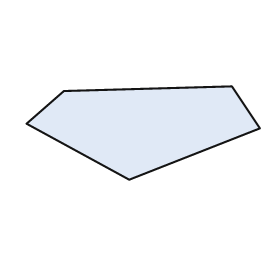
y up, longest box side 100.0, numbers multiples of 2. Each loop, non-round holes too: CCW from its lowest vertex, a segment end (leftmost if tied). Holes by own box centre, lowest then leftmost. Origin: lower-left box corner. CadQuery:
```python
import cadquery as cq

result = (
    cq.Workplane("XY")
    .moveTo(44.0, 0.0)
    .lineTo(100.0, 22.0)
    .lineTo(88.0, 40.0)
    .lineTo(16.0, 38.0)
    .lineTo(0.0, 24.0)
    .close()
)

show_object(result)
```